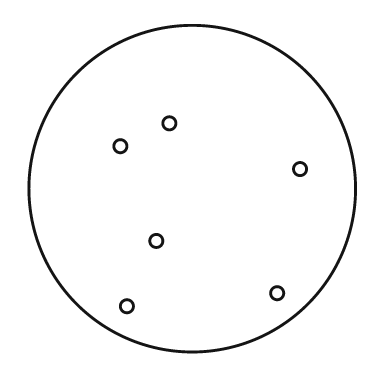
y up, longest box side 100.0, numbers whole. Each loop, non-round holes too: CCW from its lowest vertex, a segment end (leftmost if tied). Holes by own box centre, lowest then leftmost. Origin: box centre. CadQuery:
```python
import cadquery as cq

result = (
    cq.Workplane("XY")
    .moveTo(0.0, 0.0)
    .circle(50.0)
    .moveTo(-20.0, -36.0)
    .circle(2.0)
    .moveTo(26.0, -32.0)
    .circle(2.0)
    .moveTo(-11.0, -16.0)
    .circle(2.0)
    .moveTo(33.0, 6.0)
    .circle(2.0)
    .moveTo(-22.0, 13.0)
    .circle(2.0)
    .moveTo(-7.0, 20.0)
    .circle(2.0)
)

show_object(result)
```